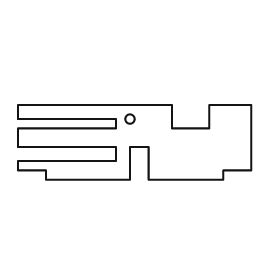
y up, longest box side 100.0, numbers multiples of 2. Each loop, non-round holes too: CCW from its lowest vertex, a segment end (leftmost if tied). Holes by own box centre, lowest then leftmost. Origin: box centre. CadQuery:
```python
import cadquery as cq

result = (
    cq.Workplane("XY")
    .moveTo(-38.0, -16.0)
    .lineTo(-2.0, -16.0)
    .lineTo(-2.0, -2.0)
    .lineTo(6.0, -2.0)
    .lineTo(6.0, -16.0)
    .lineTo(38.0, -16.0)
    .lineTo(38.0, -12.0)
    .lineTo(50.0, -12.0)
    .lineTo(50.0, 16.0)
    .lineTo(32.0, 16.0)
    .lineTo(32.0, 6.0)
    .lineTo(16.0, 6.0)
    .lineTo(16.0, 16.0)
    .lineTo(-50.0, 16.0)
    .lineTo(-50.0, 10.0)
    .lineTo(-8.0, 10.0)
    .lineTo(-8.0, 6.0)
    .lineTo(-50.0, 6.0)
    .lineTo(-50.0, -2.0)
    .lineTo(-8.0, -2.0)
    .lineTo(-8.0, -8.0)
    .lineTo(-50.0, -8.0)
    .lineTo(-50.0, -12.0)
    .lineTo(-38.0, -12.0)
    .close()
    .moveTo(-2.0, 10.0)
    .circle(2.0)
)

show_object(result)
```